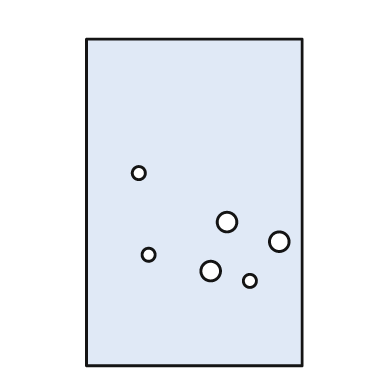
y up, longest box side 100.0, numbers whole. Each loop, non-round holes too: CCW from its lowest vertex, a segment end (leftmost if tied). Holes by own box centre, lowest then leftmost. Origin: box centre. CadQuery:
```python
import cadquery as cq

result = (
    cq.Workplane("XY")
    .moveTo(-33.0, -50.0)
    .lineTo(33.0, -50.0)
    .lineTo(33.0, 50.0)
    .lineTo(-33.0, 50.0)
    .close()
    .moveTo(17.0, -24.0)
    .circle(2.0)
    .moveTo(5.0, -21.0)
    .circle(3.0)
    .moveTo(-14.0, -16.0)
    .circle(2.0)
    .moveTo(26.0, -12.0)
    .circle(3.0)
    .moveTo(10.0, -6.0)
    .circle(3.0)
    .moveTo(-17.0, 9.0)
    .circle(2.0)
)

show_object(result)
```